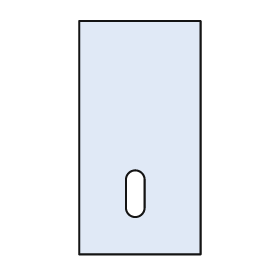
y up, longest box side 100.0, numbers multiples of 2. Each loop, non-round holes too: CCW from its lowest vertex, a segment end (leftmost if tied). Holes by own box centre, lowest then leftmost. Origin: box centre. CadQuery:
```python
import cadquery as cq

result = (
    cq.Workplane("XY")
    .moveTo(-26.0, -50.0)
    .lineTo(26.0, -50.0)
    .lineTo(26.0, 50.0)
    .lineTo(-26.0, 50.0)
    .close()
    .moveTo(-6.0, -30.0)
    .threePointArc((-2.0, -34.0), (2.0, -30.0))
    .lineTo(2.0, -18.0)
    .threePointArc((-2.0, -14.0), (-6.0, -18.0))
    .close()
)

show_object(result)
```